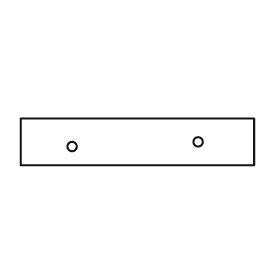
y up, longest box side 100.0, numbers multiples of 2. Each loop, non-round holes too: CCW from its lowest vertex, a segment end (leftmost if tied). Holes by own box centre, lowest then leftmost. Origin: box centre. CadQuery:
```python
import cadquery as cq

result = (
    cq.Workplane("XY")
    .moveTo(-50.0, -10.0)
    .lineTo(50.0, -10.0)
    .lineTo(50.0, 10.0)
    .lineTo(-50.0, 10.0)
    .close()
    .moveTo(-28.0, -2.0)
    .circle(2.0)
    .moveTo(26.0, 0.0)
    .circle(2.0)
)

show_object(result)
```